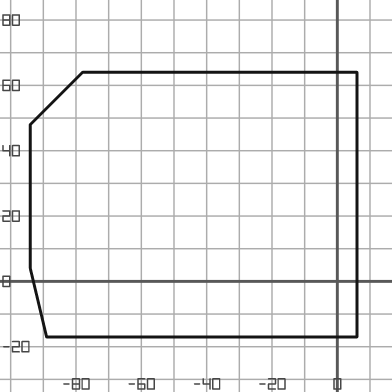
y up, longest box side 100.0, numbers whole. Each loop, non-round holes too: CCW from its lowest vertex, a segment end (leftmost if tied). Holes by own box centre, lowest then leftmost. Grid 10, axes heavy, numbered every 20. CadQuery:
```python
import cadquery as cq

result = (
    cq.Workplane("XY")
    .moveTo(-89.0, -17.0)
    .lineTo(6.0, -17.0)
    .lineTo(6.0, 64.0)
    .lineTo(-78.0, 64.0)
    .lineTo(-94.0, 48.0)
    .lineTo(-94.0, 4.0)
    .close()
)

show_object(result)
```